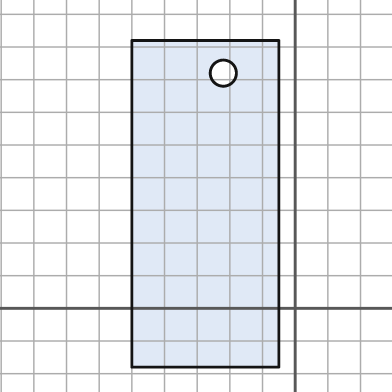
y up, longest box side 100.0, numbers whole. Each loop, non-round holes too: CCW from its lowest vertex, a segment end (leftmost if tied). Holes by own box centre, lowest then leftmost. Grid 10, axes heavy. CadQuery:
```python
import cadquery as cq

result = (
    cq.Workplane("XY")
    .moveTo(-50.0, -18.0)
    .lineTo(-5.0, -18.0)
    .lineTo(-5.0, 82.0)
    .lineTo(-50.0, 82.0)
    .close()
    .moveTo(-22.0, 72.0)
    .circle(4.0)
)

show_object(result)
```